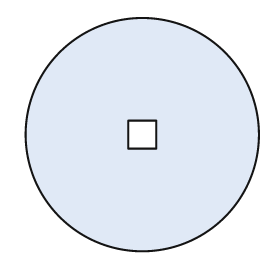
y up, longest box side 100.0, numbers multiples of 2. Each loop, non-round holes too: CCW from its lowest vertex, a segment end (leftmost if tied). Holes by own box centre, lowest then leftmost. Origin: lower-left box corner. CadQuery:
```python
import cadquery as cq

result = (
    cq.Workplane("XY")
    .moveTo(50.0, 50.0)
    .circle(50.0)
    .moveTo(44.0, 44.0)
    .lineTo(56.0, 44.0)
    .lineTo(56.0, 56.0)
    .lineTo(44.0, 56.0)
    .close()
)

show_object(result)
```